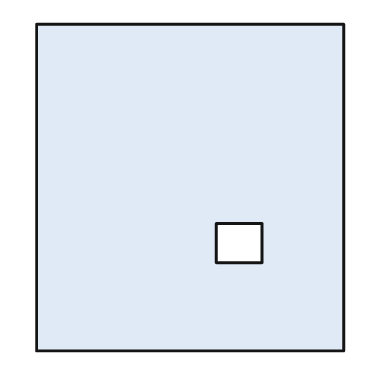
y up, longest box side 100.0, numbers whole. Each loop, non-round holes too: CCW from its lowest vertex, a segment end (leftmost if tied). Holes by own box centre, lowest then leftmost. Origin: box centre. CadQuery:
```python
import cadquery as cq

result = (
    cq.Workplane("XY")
    .moveTo(-47.0, -50.0)
    .lineTo(47.0, -50.0)
    .lineTo(47.0, 50.0)
    .lineTo(-47.0, 50.0)
    .close()
    .moveTo(8.0, -23.0)
    .lineTo(22.0, -23.0)
    .lineTo(22.0, -11.0)
    .lineTo(8.0, -11.0)
    .close()
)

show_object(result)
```